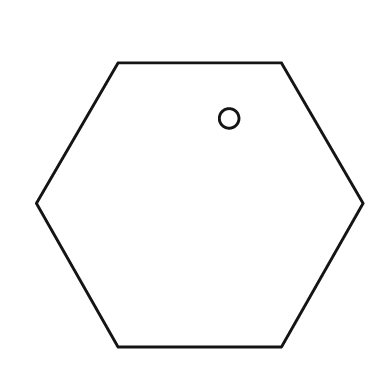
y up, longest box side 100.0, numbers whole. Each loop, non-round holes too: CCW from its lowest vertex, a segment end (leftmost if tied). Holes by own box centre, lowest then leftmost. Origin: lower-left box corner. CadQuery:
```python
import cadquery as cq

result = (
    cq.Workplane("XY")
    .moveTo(25.0, 0.0)
    .lineTo(75.0, 0.0)
    .lineTo(100.0, 44.0)
    .lineTo(75.0, 87.0)
    .lineTo(25.0, 87.0)
    .lineTo(0.0, 44.0)
    .close()
    .moveTo(59.0, 70.0)
    .circle(3.0)
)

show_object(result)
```